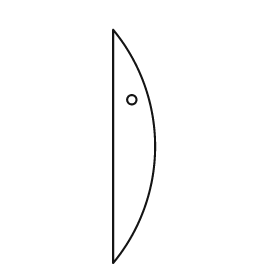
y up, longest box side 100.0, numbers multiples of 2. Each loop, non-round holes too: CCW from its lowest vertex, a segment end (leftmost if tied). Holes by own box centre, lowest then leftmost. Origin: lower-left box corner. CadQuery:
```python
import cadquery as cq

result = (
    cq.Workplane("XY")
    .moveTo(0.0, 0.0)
    .threePointArc((18.0, 50.0), (0.0, 100.0))
    .close()
    .moveTo(8.0, 70.0)
    .circle(2.0)
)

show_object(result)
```